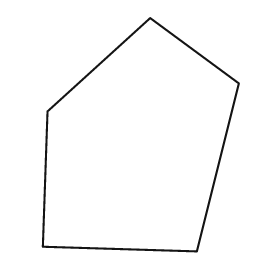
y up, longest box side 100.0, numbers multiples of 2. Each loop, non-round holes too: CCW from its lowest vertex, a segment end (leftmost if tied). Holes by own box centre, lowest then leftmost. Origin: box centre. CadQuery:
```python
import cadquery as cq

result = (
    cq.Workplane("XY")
    .moveTo(24.0, -50.0)
    .lineTo(42.0, 22.0)
    .lineTo(4.0, 50.0)
    .lineTo(-40.0, 10.0)
    .lineTo(-42.0, -48.0)
    .close()
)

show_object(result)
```